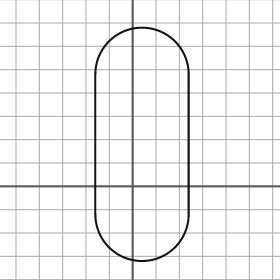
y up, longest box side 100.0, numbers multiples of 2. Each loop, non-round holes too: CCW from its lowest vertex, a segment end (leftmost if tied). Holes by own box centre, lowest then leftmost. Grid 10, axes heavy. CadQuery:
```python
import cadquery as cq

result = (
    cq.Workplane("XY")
    .moveTo(-16.0, -12.0)
    .threePointArc((4.0, -32.0), (24.0, -12.0))
    .lineTo(24.0, 48.0)
    .threePointArc((4.0, 68.0), (-16.0, 48.0))
    .close()
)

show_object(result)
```